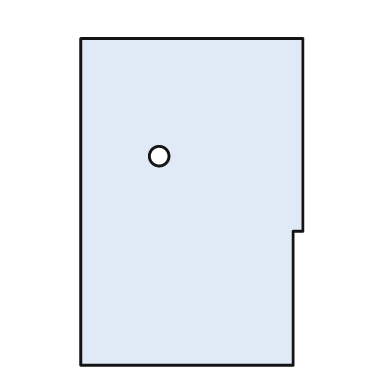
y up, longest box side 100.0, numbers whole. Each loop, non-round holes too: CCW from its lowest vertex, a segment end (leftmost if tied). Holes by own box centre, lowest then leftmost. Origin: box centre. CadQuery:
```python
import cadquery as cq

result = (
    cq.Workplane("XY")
    .moveTo(-34.0, -50.0)
    .lineTo(31.0, -50.0)
    .lineTo(31.0, -9.0)
    .lineTo(34.0, -9.0)
    .lineTo(34.0, 50.0)
    .lineTo(-34.0, 50.0)
    .close()
    .moveTo(-10.0, 14.0)
    .circle(3.0)
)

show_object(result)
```